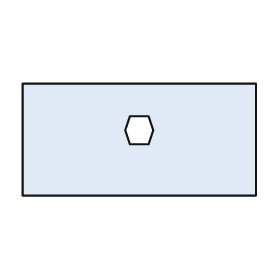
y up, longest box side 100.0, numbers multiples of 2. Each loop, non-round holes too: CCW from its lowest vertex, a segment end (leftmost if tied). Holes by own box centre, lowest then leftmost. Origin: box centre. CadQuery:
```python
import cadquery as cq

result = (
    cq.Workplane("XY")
    .moveTo(-50.0, -24.0)
    .lineTo(50.0, -24.0)
    .lineTo(50.0, 24.0)
    .lineTo(-50.0, 24.0)
    .close()
    .moveTo(-4.0, -2.0)
    .lineTo(4.0, -2.0)
    .lineTo(6.0, 4.0)
    .lineTo(4.0, 10.0)
    .lineTo(-4.0, 10.0)
    .lineTo(-6.0, 4.0)
    .close()
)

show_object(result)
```